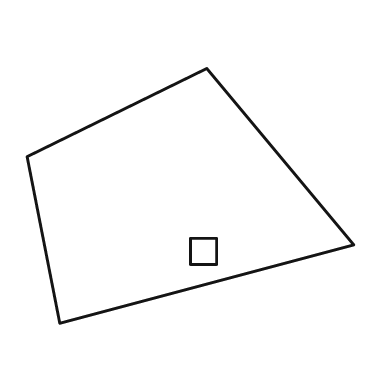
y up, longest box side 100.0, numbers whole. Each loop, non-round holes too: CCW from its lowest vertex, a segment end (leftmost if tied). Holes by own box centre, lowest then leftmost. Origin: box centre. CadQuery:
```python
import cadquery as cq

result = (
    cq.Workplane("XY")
    .moveTo(-40.0, -39.0)
    .lineTo(50.0, -15.0)
    .lineTo(5.0, 39.0)
    .lineTo(-50.0, 12.0)
    .close()
    .moveTo(0.0, -21.0)
    .lineTo(8.0, -21.0)
    .lineTo(8.0, -13.0)
    .lineTo(0.0, -13.0)
    .close()
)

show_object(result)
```